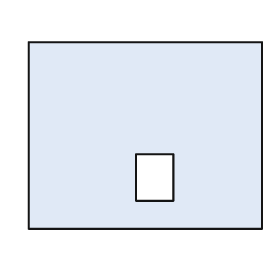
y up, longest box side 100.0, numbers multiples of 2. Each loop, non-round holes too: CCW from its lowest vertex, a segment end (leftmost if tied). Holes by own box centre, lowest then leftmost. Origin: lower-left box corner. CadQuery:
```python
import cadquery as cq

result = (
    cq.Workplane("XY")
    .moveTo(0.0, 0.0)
    .lineTo(100.0, 0.0)
    .lineTo(100.0, 80.0)
    .lineTo(0.0, 80.0)
    .close()
    .moveTo(46.0, 12.0)
    .lineTo(62.0, 12.0)
    .lineTo(62.0, 32.0)
    .lineTo(46.0, 32.0)
    .close()
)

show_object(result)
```